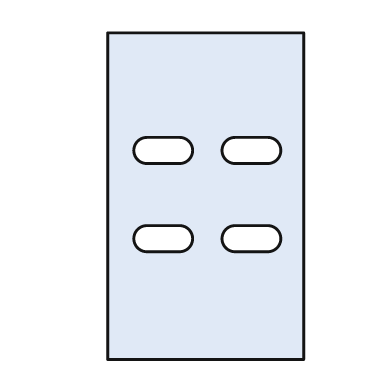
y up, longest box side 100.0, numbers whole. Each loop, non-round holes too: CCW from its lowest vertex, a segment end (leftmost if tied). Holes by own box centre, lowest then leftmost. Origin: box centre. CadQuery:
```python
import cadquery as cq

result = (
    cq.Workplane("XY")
    .moveTo(-30.0, -50.0)
    .lineTo(30.0, -50.0)
    .lineTo(30.0, 50.0)
    .lineTo(-30.0, 50.0)
    .close()
    .moveTo(-18.0, -17.0)
    .lineTo(-8.0, -17.0)
    .threePointArc((-4.0, -13.0), (-8.0, -9.0))
    .lineTo(-18.0, -9.0)
    .threePointArc((-22.0, -13.0), (-18.0, -17.0))
    .close()
    .moveTo(9.0, -17.0)
    .lineTo(19.0, -17.0)
    .threePointArc((23.0, -13.0), (19.0, -9.0))
    .lineTo(9.0, -9.0)
    .threePointArc((5.0, -13.0), (9.0, -17.0))
    .close()
    .moveTo(-18.0, 10.0)
    .lineTo(-8.0, 10.0)
    .threePointArc((-4.0, 14.0), (-8.0, 18.0))
    .lineTo(-18.0, 18.0)
    .threePointArc((-22.0, 14.0), (-18.0, 10.0))
    .close()
    .moveTo(9.0, 10.0)
    .lineTo(19.0, 10.0)
    .threePointArc((23.0, 14.0), (19.0, 18.0))
    .lineTo(9.0, 18.0)
    .threePointArc((5.0, 14.0), (9.0, 10.0))
    .close()
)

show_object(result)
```